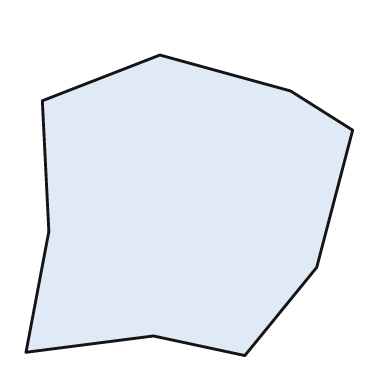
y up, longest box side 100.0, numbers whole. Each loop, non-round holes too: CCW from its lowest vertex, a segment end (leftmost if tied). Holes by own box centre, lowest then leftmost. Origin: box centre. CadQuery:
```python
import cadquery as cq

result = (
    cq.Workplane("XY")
    .moveTo(17.0, -46.0)
    .lineTo(39.0, -19.0)
    .lineTo(50.0, 23.0)
    .lineTo(31.0, 35.0)
    .lineTo(-9.0, 46.0)
    .lineTo(-45.0, 32.0)
    .lineTo(-43.0, -8.0)
    .lineTo(-50.0, -45.0)
    .lineTo(-11.0, -40.0)
    .close()
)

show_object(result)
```